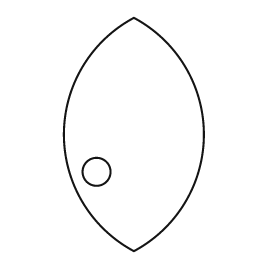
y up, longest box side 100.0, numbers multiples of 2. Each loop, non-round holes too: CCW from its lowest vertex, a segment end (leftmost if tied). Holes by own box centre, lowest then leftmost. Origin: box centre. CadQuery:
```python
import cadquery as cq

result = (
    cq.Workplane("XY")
    .moveTo(0.0, -50.0)
    .threePointArc((30.0, 0.0), (0.0, 50.0))
    .threePointArc((-30.0, 0.0), (0.0, -50.0))
    .close()
    .moveTo(-16.0, -16.0)
    .circle(6.0)
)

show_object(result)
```